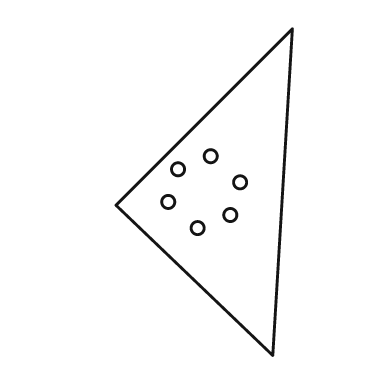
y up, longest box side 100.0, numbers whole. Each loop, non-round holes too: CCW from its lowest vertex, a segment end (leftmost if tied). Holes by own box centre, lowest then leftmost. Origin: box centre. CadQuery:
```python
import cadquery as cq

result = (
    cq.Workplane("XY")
    .moveTo(21.0, -50.0)
    .lineTo(27.0, 50.0)
    .lineTo(-27.0, -4.0)
    .close()
    .moveTo(-2.0, -11.0)
    .circle(2.0)
    .moveTo(8.0, -7.0)
    .circle(2.0)
    .moveTo(-11.0, -3.0)
    .circle(2.0)
    .moveTo(11.0, 3.0)
    .circle(2.0)
    .moveTo(-8.0, 7.0)
    .circle(2.0)
    .moveTo(2.0, 11.0)
    .circle(2.0)
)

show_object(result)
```